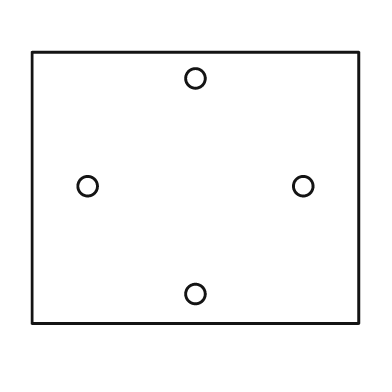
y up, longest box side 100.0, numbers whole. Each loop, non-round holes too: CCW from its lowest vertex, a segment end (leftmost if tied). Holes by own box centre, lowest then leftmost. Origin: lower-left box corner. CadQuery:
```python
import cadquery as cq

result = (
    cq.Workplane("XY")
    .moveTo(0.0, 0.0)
    .lineTo(100.0, 0.0)
    .lineTo(100.0, 83.0)
    .lineTo(0.0, 83.0)
    .close()
    .moveTo(50.0, 9.0)
    .circle(3.0)
    .moveTo(17.0, 42.0)
    .circle(3.0)
    .moveTo(83.0, 42.0)
    .circle(3.0)
    .moveTo(50.0, 75.0)
    .circle(3.0)
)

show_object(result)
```